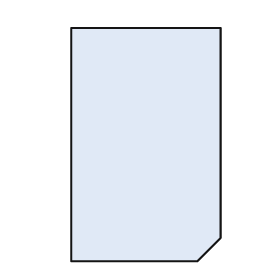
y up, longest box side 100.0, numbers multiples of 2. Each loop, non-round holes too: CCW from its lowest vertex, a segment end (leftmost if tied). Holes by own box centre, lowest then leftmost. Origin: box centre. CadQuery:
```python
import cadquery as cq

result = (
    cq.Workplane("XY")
    .moveTo(-32.0, -50.0)
    .lineTo(22.0, -50.0)
    .lineTo(32.0, -40.0)
    .lineTo(32.0, 50.0)
    .lineTo(-32.0, 50.0)
    .close()
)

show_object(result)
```